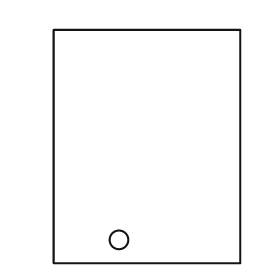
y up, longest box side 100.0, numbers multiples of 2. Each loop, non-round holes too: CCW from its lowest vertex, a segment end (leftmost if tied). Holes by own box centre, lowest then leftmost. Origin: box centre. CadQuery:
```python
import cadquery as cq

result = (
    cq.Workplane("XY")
    .moveTo(-40.0, -50.0)
    .lineTo(40.0, -50.0)
    .lineTo(40.0, 50.0)
    .lineTo(-40.0, 50.0)
    .close()
    .moveTo(-12.0, -40.0)
    .circle(4.0)
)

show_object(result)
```